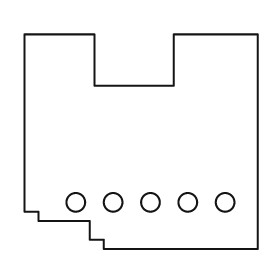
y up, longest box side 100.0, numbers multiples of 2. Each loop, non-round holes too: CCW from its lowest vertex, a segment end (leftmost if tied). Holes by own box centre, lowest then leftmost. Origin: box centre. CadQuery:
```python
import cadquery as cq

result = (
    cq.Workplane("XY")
    .moveTo(-16.0, -46.0)
    .lineTo(50.0, -46.0)
    .lineTo(50.0, 46.0)
    .lineTo(14.0, 46.0)
    .lineTo(14.0, 24.0)
    .lineTo(-20.0, 24.0)
    .lineTo(-20.0, 46.0)
    .lineTo(-50.0, 46.0)
    .lineTo(-50.0, -30.0)
    .lineTo(-44.0, -30.0)
    .lineTo(-44.0, -34.0)
    .lineTo(-22.0, -34.0)
    .lineTo(-22.0, -42.0)
    .lineTo(-16.0, -42.0)
    .close()
    .moveTo(-28.0, -26.0)
    .circle(4.0)
    .moveTo(-12.0, -26.0)
    .circle(4.0)
    .moveTo(4.0, -26.0)
    .circle(4.0)
    .moveTo(20.0, -26.0)
    .circle(4.0)
    .moveTo(36.0, -26.0)
    .circle(4.0)
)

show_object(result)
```